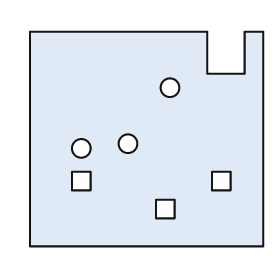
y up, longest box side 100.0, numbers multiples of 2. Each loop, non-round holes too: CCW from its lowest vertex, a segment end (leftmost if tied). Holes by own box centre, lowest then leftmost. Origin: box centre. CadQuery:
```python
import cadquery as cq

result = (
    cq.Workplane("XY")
    .moveTo(-50.0, -46.0)
    .lineTo(50.0, -46.0)
    .lineTo(50.0, 46.0)
    .lineTo(42.0, 46.0)
    .lineTo(42.0, 28.0)
    .lineTo(26.0, 28.0)
    .lineTo(26.0, 46.0)
    .lineTo(-50.0, 46.0)
    .close()
    .moveTo(4.0, -34.0)
    .lineTo(12.0, -34.0)
    .lineTo(12.0, -26.0)
    .lineTo(4.0, -26.0)
    .close()
    .moveTo(-32.0, -22.0)
    .lineTo(-24.0, -22.0)
    .lineTo(-24.0, -14.0)
    .lineTo(-32.0, -14.0)
    .close()
    .moveTo(28.0, -22.0)
    .lineTo(36.0, -22.0)
    .lineTo(36.0, -14.0)
    .lineTo(28.0, -14.0)
    .close()
    .moveTo(-28.0, -4.0)
    .circle(4.0)
    .moveTo(-8.0, -2.0)
    .circle(4.0)
    .moveTo(10.0, 22.0)
    .circle(4.0)
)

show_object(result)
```